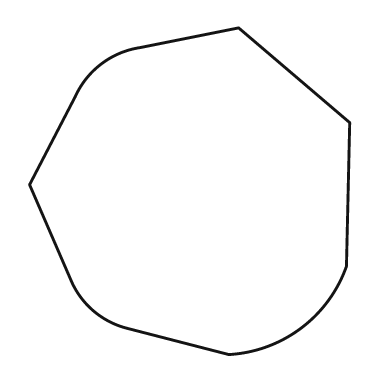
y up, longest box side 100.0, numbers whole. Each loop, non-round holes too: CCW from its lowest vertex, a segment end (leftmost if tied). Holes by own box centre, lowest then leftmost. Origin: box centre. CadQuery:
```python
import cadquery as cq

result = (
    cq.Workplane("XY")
    .moveTo(12.0, -50.0)
    .threePointArc((34.0, -42.0), (48.0, -23.0))
    .lineTo(49.0, 21.0)
    .lineTo(15.0, 50.0)
    .lineTo(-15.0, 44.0)
    .threePointArc((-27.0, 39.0), (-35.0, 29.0))
    .lineTo(-49.0, 2.0)
    .lineTo(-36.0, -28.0)
    .threePointArc((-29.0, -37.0), (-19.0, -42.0))
    .close()
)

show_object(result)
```